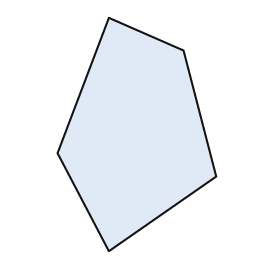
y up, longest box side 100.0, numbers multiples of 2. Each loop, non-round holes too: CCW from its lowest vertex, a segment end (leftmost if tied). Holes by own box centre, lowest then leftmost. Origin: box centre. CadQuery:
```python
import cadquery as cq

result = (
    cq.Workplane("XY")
    .moveTo(-12.0, -50.0)
    .lineTo(34.0, -18.0)
    .lineTo(20.0, 36.0)
    .lineTo(-12.0, 50.0)
    .lineTo(-34.0, -8.0)
    .close()
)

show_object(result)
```